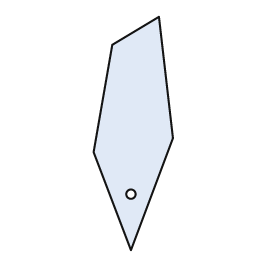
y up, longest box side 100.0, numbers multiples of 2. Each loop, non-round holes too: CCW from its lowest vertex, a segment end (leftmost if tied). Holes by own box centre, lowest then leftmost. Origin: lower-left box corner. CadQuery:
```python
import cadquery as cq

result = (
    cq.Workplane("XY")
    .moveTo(16.0, 0.0)
    .lineTo(34.0, 48.0)
    .lineTo(28.0, 100.0)
    .lineTo(8.0, 88.0)
    .lineTo(0.0, 42.0)
    .close()
    .moveTo(16.0, 24.0)
    .circle(2.0)
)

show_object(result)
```